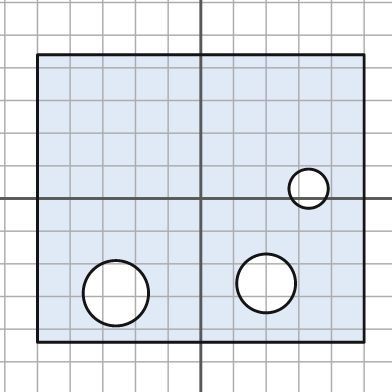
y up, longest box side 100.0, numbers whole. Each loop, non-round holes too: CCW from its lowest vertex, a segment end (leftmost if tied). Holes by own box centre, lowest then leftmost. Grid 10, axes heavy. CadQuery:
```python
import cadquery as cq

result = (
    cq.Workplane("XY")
    .moveTo(-50.0, -44.0)
    .lineTo(50.0, -44.0)
    .lineTo(50.0, 44.0)
    .lineTo(-50.0, 44.0)
    .close()
    .moveTo(-26.0, -29.0)
    .circle(10.0)
    .moveTo(20.0, -26.0)
    .circle(9.0)
    .moveTo(33.0, 3.0)
    .circle(6.0)
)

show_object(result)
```